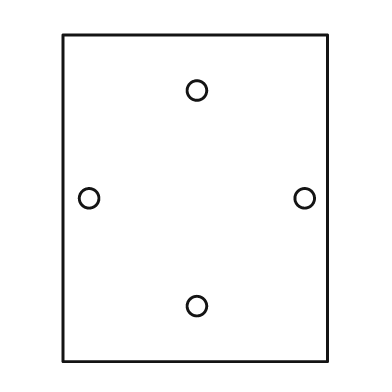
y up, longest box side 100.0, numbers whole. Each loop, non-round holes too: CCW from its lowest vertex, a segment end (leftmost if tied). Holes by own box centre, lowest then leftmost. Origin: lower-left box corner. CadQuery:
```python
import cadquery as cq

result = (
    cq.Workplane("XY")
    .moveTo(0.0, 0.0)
    .lineTo(81.0, 0.0)
    .lineTo(81.0, 100.0)
    .lineTo(0.0, 100.0)
    .close()
    .moveTo(41.0, 17.0)
    .circle(3.0)
    .moveTo(8.0, 50.0)
    .circle(3.0)
    .moveTo(74.0, 50.0)
    .circle(3.0)
    .moveTo(41.0, 83.0)
    .circle(3.0)
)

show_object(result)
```